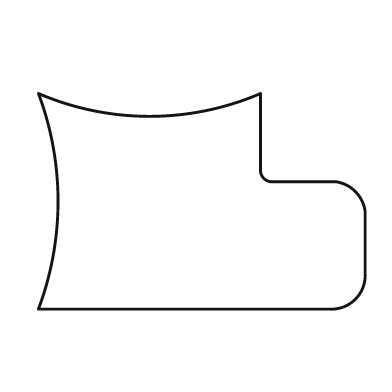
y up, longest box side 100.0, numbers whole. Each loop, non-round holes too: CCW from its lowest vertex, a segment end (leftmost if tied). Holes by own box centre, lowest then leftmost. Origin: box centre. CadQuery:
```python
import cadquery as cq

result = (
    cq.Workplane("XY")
    .moveTo(-50.0, -33.0)
    .lineTo(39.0, -33.0)
    .threePointArc((47.0, -30.0), (50.0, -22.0))
    .lineTo(50.0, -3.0)
    .threePointArc((47.0, 3.0), (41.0, 6.0))
    .lineTo(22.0, 6.0)
    .threePointArc((19.0, 7.0), (18.0, 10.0))
    .lineTo(18.0, 33.0)
    .threePointArc((-16.0, 26.0), (-50.0, 33.0))
    .threePointArc((-44.0, 0.0), (-50.0, -33.0))
    .close()
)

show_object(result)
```